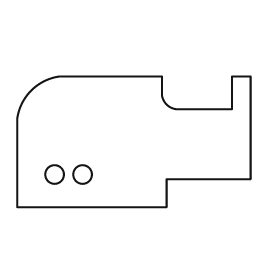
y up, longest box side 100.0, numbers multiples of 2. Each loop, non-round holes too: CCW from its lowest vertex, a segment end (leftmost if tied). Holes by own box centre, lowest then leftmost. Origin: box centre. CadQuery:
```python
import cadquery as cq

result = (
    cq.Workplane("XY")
    .moveTo(-50.0, -28.0)
    .lineTo(14.0, -28.0)
    .lineTo(14.0, -16.0)
    .lineTo(50.0, -16.0)
    .lineTo(50.0, 28.0)
    .lineTo(42.0, 28.0)
    .lineTo(42.0, 14.0)
    .lineTo(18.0, 14.0)
    .threePointArc((14.0, 16.0), (12.0, 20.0))
    .lineTo(12.0, 28.0)
    .lineTo(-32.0, 28.0)
    .threePointArc((-44.0, 22.0), (-50.0, 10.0))
    .close()
    .moveTo(-34.0, -14.0)
    .circle(4.0)
    .moveTo(-22.0, -14.0)
    .circle(4.0)
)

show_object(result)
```